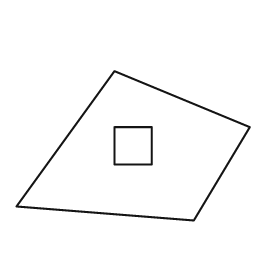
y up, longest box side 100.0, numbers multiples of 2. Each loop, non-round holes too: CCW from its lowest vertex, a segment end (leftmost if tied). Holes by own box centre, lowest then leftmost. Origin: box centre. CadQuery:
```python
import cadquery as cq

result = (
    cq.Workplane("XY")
    .moveTo(26.0, -32.0)
    .lineTo(50.0, 8.0)
    .lineTo(-8.0, 32.0)
    .lineTo(-50.0, -26.0)
    .close()
    .moveTo(-8.0, -8.0)
    .lineTo(8.0, -8.0)
    .lineTo(8.0, 8.0)
    .lineTo(-8.0, 8.0)
    .close()
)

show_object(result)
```